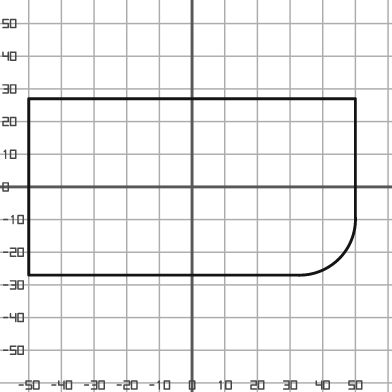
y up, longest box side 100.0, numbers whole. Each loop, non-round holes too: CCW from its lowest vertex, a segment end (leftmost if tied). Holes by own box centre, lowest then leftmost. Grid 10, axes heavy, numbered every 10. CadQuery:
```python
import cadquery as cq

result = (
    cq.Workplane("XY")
    .moveTo(-50.0, -27.0)
    .lineTo(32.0, -27.0)
    .threePointArc((45.0, -22.0), (50.0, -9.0))
    .lineTo(50.0, 27.0)
    .lineTo(-50.0, 27.0)
    .close()
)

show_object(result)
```